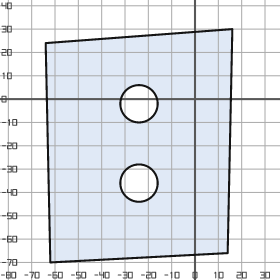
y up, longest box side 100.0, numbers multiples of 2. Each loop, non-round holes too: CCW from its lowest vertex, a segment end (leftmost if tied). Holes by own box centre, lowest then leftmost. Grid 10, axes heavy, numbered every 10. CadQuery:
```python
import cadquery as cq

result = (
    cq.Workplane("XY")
    .moveTo(-62.0, -70.0)
    .lineTo(14.0, -66.0)
    .lineTo(16.0, 30.0)
    .lineTo(-64.0, 24.0)
    .close()
    .moveTo(-24.0, -36.0)
    .circle(8.0)
    .moveTo(-24.0, -2.0)
    .circle(8.0)
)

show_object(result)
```